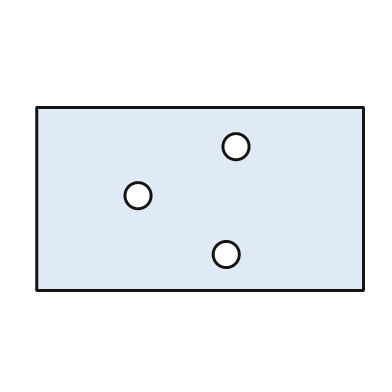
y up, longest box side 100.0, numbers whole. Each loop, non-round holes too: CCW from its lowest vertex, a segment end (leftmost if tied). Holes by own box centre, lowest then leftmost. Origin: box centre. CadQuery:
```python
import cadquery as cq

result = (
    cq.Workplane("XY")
    .moveTo(-50.0, -28.0)
    .lineTo(50.0, -28.0)
    .lineTo(50.0, 28.0)
    .lineTo(-50.0, 28.0)
    .close()
    .moveTo(8.0, -17.0)
    .circle(4.0)
    .moveTo(-19.0, 1.0)
    .circle(4.0)
    .moveTo(11.0, 16.0)
    .circle(4.0)
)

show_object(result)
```